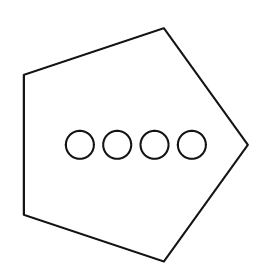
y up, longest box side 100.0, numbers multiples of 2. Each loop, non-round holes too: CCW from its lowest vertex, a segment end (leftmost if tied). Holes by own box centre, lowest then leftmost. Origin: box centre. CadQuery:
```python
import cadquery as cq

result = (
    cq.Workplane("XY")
    .moveTo(12.0, -50.0)
    .lineTo(48.0, 0.0)
    .lineTo(12.0, 50.0)
    .lineTo(-48.0, 30.0)
    .lineTo(-48.0, -30.0)
    .close()
    .moveTo(-24.0, 0.0)
    .circle(6.0)
    .moveTo(-8.0, 0.0)
    .circle(6.0)
    .moveTo(8.0, 0.0)
    .circle(6.0)
    .moveTo(24.0, 0.0)
    .circle(6.0)
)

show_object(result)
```